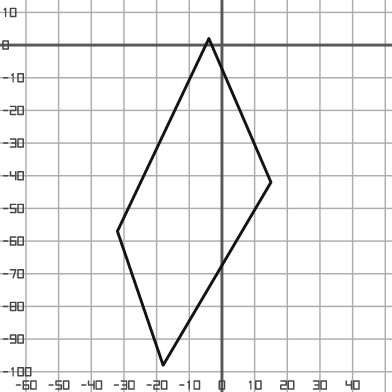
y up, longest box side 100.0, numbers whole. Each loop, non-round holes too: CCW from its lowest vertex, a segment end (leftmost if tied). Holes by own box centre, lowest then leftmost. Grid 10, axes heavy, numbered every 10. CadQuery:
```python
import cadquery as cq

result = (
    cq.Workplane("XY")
    .moveTo(-18.0, -98.0)
    .lineTo(15.0, -42.0)
    .lineTo(-4.0, 2.0)
    .lineTo(-32.0, -57.0)
    .close()
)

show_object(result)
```